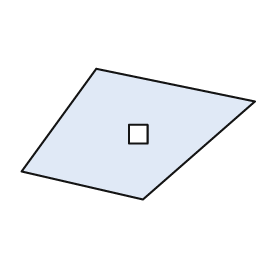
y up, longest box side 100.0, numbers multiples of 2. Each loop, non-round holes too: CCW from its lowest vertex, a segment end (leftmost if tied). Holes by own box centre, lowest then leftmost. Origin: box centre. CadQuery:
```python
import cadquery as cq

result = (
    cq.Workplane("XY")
    .moveTo(2.0, -28.0)
    .lineTo(50.0, 14.0)
    .lineTo(-18.0, 28.0)
    .lineTo(-50.0, -16.0)
    .close()
    .moveTo(-4.0, -4.0)
    .lineTo(4.0, -4.0)
    .lineTo(4.0, 4.0)
    .lineTo(-4.0, 4.0)
    .close()
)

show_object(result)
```